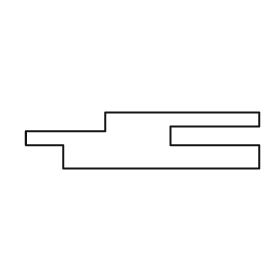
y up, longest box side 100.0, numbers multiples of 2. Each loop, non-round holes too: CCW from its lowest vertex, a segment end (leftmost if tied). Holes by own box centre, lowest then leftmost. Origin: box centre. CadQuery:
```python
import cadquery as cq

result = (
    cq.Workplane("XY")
    .moveTo(-34.0, -12.0)
    .lineTo(50.0, -12.0)
    .lineTo(50.0, -2.0)
    .lineTo(12.0, -2.0)
    .lineTo(12.0, 6.0)
    .lineTo(50.0, 6.0)
    .lineTo(50.0, 12.0)
    .lineTo(-16.0, 12.0)
    .lineTo(-16.0, 4.0)
    .lineTo(-50.0, 4.0)
    .lineTo(-50.0, -2.0)
    .lineTo(-34.0, -2.0)
    .close()
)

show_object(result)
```